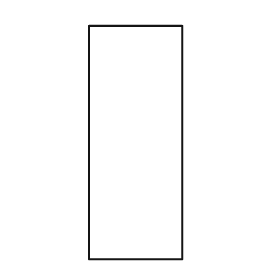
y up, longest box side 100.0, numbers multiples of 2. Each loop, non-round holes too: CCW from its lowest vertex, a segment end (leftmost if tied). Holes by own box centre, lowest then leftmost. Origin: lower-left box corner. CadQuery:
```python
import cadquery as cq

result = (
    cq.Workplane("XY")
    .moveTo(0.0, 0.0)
    .lineTo(40.0, 0.0)
    .lineTo(40.0, 100.0)
    .lineTo(0.0, 100.0)
    .close()
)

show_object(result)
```